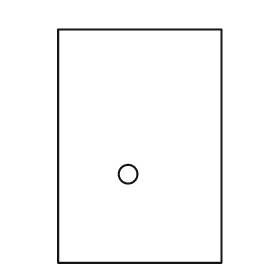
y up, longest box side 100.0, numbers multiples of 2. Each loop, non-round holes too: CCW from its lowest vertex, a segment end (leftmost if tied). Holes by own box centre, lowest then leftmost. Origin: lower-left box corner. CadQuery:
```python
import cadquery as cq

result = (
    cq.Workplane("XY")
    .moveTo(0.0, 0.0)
    .lineTo(70.0, 0.0)
    .lineTo(70.0, 100.0)
    .lineTo(0.0, 100.0)
    .close()
    .moveTo(30.0, 38.0)
    .circle(4.0)
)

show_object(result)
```